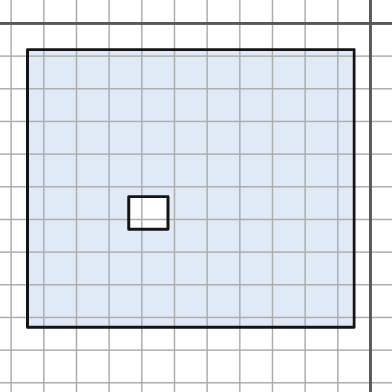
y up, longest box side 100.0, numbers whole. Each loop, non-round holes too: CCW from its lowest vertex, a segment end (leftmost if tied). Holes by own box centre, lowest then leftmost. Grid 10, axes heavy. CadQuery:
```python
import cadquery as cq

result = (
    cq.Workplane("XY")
    .moveTo(-105.0, -93.0)
    .lineTo(-5.0, -93.0)
    .lineTo(-5.0, -8.0)
    .lineTo(-105.0, -8.0)
    .close()
    .moveTo(-74.0, -63.0)
    .lineTo(-62.0, -63.0)
    .lineTo(-62.0, -53.0)
    .lineTo(-74.0, -53.0)
    .close()
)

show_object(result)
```